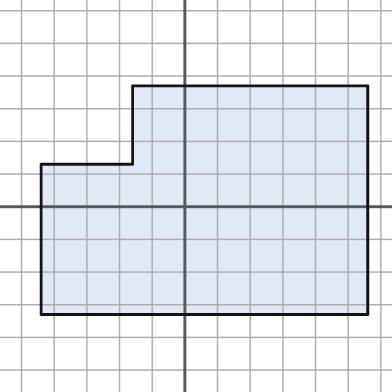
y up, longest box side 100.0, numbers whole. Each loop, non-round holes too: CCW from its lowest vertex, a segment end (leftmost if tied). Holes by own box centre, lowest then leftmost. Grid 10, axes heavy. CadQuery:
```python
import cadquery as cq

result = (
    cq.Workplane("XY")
    .moveTo(-44.0, -33.0)
    .lineTo(56.0, -33.0)
    .lineTo(56.0, 37.0)
    .lineTo(-16.0, 37.0)
    .lineTo(-16.0, 13.0)
    .lineTo(-44.0, 13.0)
    .close()
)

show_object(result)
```